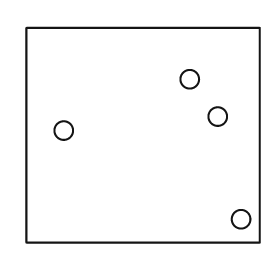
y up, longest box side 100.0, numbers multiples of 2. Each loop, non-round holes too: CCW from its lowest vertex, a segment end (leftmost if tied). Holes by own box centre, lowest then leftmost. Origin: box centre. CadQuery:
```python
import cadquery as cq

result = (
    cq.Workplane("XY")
    .moveTo(-50.0, -46.0)
    .lineTo(50.0, -46.0)
    .lineTo(50.0, 46.0)
    .lineTo(-50.0, 46.0)
    .close()
    .moveTo(42.0, -36.0)
    .circle(4.0)
    .moveTo(-34.0, 2.0)
    .circle(4.0)
    .moveTo(32.0, 8.0)
    .circle(4.0)
    .moveTo(20.0, 24.0)
    .circle(4.0)
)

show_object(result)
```